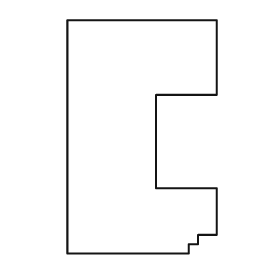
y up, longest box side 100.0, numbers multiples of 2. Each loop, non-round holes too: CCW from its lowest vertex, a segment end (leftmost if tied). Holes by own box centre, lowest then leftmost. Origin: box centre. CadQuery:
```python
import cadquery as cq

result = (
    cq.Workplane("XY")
    .moveTo(-32.0, -50.0)
    .lineTo(20.0, -50.0)
    .lineTo(20.0, -46.0)
    .lineTo(24.0, -46.0)
    .lineTo(24.0, -42.0)
    .lineTo(32.0, -42.0)
    .lineTo(32.0, -22.0)
    .lineTo(6.0, -22.0)
    .lineTo(6.0, 18.0)
    .lineTo(32.0, 18.0)
    .lineTo(32.0, 50.0)
    .lineTo(-32.0, 50.0)
    .close()
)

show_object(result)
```